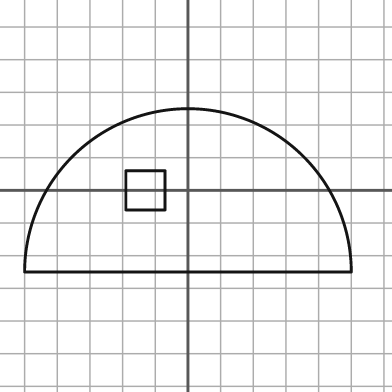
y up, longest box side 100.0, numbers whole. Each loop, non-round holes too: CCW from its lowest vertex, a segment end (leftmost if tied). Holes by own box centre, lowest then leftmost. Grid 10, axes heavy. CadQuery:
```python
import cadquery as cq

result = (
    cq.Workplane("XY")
    .moveTo(-50.0, -25.0)
    .lineTo(50.0, -25.0)
    .threePointArc((0.0, 25.0), (-50.0, -25.0))
    .close()
    .moveTo(-19.0, -6.0)
    .lineTo(-7.0, -6.0)
    .lineTo(-7.0, 6.0)
    .lineTo(-19.0, 6.0)
    .close()
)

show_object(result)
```